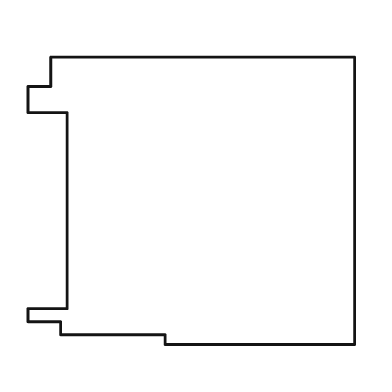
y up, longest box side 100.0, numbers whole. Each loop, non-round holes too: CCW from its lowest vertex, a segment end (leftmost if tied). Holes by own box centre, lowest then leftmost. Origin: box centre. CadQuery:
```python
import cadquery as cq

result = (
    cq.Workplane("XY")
    .moveTo(-8.0, -44.0)
    .lineTo(50.0, -44.0)
    .lineTo(50.0, 44.0)
    .lineTo(-43.0, 44.0)
    .lineTo(-43.0, 35.0)
    .lineTo(-50.0, 35.0)
    .lineTo(-50.0, 27.0)
    .lineTo(-38.0, 27.0)
    .lineTo(-38.0, -33.0)
    .lineTo(-50.0, -33.0)
    .lineTo(-50.0, -37.0)
    .lineTo(-40.0, -37.0)
    .lineTo(-40.0, -41.0)
    .lineTo(-8.0, -41.0)
    .close()
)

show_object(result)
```